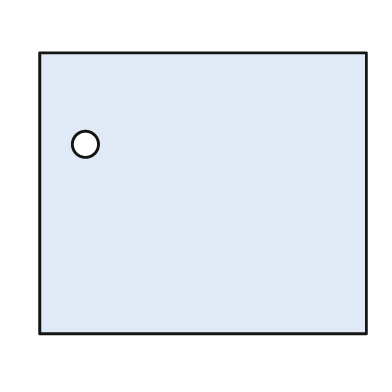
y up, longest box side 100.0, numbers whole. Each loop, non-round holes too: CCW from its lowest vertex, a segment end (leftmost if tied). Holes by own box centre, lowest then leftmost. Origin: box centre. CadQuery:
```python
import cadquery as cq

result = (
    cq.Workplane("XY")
    .moveTo(-50.0, -43.0)
    .lineTo(50.0, -43.0)
    .lineTo(50.0, 43.0)
    .lineTo(-50.0, 43.0)
    .close()
    .moveTo(-36.0, 15.0)
    .circle(4.0)
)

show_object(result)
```